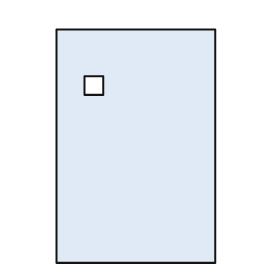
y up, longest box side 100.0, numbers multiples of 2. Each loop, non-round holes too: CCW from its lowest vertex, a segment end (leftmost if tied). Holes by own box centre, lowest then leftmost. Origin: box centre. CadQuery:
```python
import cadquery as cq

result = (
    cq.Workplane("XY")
    .moveTo(-34.0, -50.0)
    .lineTo(34.0, -50.0)
    .lineTo(34.0, 50.0)
    .lineTo(-34.0, 50.0)
    .close()
    .moveTo(-22.0, 22.0)
    .lineTo(-14.0, 22.0)
    .lineTo(-14.0, 30.0)
    .lineTo(-22.0, 30.0)
    .close()
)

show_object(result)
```